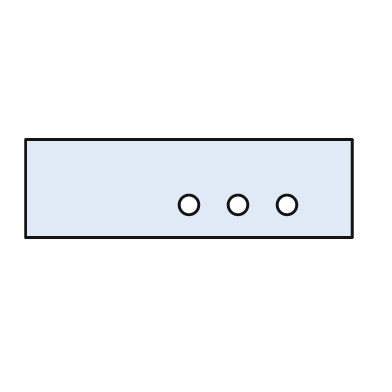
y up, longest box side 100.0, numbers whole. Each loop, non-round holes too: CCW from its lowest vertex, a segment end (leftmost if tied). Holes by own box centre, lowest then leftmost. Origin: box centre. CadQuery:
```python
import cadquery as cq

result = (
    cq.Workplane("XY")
    .moveTo(-50.0, -15.0)
    .lineTo(50.0, -15.0)
    .lineTo(50.0, 15.0)
    .lineTo(-50.0, 15.0)
    .close()
    .moveTo(0.0, -5.0)
    .circle(3.0)
    .moveTo(15.0, -5.0)
    .circle(3.0)
    .moveTo(30.0, -5.0)
    .circle(3.0)
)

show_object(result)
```